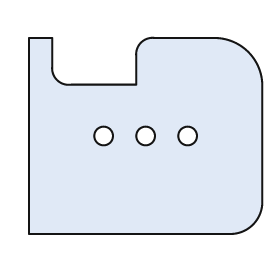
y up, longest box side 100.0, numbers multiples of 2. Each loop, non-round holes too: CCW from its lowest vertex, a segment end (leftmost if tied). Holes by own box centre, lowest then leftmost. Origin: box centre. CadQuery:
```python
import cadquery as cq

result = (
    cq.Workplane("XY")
    .moveTo(-50.0, -42.0)
    .lineTo(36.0, -42.0)
    .threePointArc((46.0, -38.0), (50.0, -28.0))
    .lineTo(50.0, 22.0)
    .threePointArc((44.0, 36.0), (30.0, 42.0))
    .lineTo(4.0, 42.0)
    .threePointArc((-2.0, 40.0), (-4.0, 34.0))
    .lineTo(-4.0, 22.0)
    .lineTo(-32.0, 22.0)
    .threePointArc((-38.0, 24.0), (-40.0, 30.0))
    .lineTo(-40.0, 42.0)
    .lineTo(-50.0, 42.0)
    .close()
    .moveTo(-18.0, 0.0)
    .circle(4.0)
    .moveTo(0.0, 0.0)
    .circle(4.0)
    .moveTo(18.0, 0.0)
    .circle(4.0)
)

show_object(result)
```